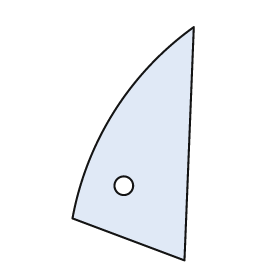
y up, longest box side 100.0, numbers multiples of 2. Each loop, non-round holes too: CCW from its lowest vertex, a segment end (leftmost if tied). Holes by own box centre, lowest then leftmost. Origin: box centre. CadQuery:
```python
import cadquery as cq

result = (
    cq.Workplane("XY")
    .moveTo(22.0, -50.0)
    .lineTo(26.0, 50.0)
    .threePointArc((-8.0, 14.0), (-26.0, -32.0))
    .close()
    .moveTo(-4.0, -18.0)
    .circle(4.0)
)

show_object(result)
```